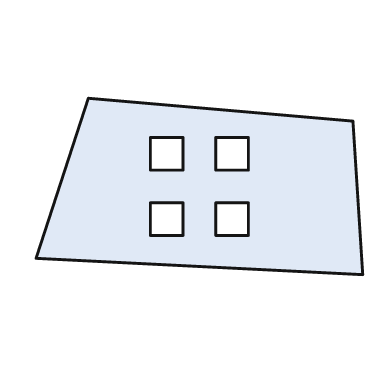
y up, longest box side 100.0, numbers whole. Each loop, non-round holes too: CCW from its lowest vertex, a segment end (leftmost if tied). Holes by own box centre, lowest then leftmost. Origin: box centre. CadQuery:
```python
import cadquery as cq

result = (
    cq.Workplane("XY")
    .moveTo(50.0, -27.0)
    .lineTo(47.0, 20.0)
    .lineTo(-34.0, 27.0)
    .lineTo(-50.0, -22.0)
    .close()
    .moveTo(-15.0, -15.0)
    .lineTo(-5.0, -15.0)
    .lineTo(-5.0, -5.0)
    .lineTo(-15.0, -5.0)
    .close()
    .moveTo(5.0, -15.0)
    .lineTo(15.0, -15.0)
    .lineTo(15.0, -5.0)
    .lineTo(5.0, -5.0)
    .close()
    .moveTo(-15.0, 5.0)
    .lineTo(-5.0, 5.0)
    .lineTo(-5.0, 15.0)
    .lineTo(-15.0, 15.0)
    .close()
    .moveTo(5.0, 5.0)
    .lineTo(15.0, 5.0)
    .lineTo(15.0, 15.0)
    .lineTo(5.0, 15.0)
    .close()
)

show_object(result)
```